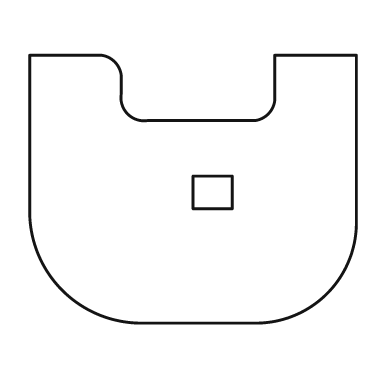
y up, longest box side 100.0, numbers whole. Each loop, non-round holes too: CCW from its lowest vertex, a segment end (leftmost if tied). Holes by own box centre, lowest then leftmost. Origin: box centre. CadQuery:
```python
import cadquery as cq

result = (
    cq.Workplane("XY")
    .moveTo(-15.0, -41.0)
    .lineTo(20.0, -41.0)
    .threePointArc((41.0, -32.0), (50.0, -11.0))
    .lineTo(50.0, 41.0)
    .lineTo(25.0, 41.0)
    .lineTo(25.0, 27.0)
    .threePointArc((23.0, 23.0), (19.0, 21.0))
    .lineTo(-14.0, 21.0)
    .threePointArc((-20.0, 23.0), (-22.0, 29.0))
    .lineTo(-22.0, 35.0)
    .threePointArc((-24.0, 39.0), (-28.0, 41.0))
    .lineTo(-50.0, 41.0)
    .lineTo(-50.0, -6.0)
    .threePointArc((-40.0, -31.0), (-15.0, -41.0))
    .close()
    .moveTo(0.0, -6.0)
    .lineTo(12.0, -6.0)
    .lineTo(12.0, 4.0)
    .lineTo(0.0, 4.0)
    .close()
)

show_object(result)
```